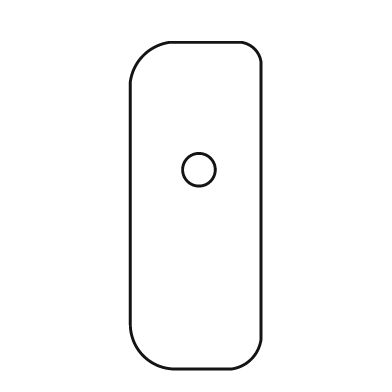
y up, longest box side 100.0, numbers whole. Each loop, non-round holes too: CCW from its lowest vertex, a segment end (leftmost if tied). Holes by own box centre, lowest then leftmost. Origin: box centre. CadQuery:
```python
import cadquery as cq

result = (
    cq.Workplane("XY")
    .moveTo(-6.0, -50.0)
    .lineTo(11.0, -50.0)
    .threePointArc((17.0, -47.0), (20.0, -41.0))
    .lineTo(20.0, 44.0)
    .threePointArc((18.0, 48.0), (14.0, 50.0))
    .lineTo(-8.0, 50.0)
    .threePointArc((-16.0, 46.0), (-20.0, 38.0))
    .lineTo(-20.0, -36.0)
    .threePointArc((-16.0, -46.0), (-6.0, -50.0))
    .close()
    .moveTo(1.0, 11.0)
    .circle(5.0)
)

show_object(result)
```